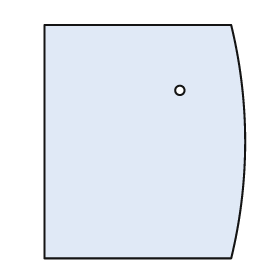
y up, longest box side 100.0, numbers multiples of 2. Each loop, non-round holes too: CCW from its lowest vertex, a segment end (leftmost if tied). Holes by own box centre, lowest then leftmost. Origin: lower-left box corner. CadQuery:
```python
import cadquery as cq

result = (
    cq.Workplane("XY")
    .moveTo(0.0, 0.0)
    .lineTo(80.0, 0.0)
    .threePointArc((86.0, 50.0), (80.0, 100.0))
    .lineTo(0.0, 100.0)
    .close()
    .moveTo(58.0, 72.0)
    .circle(2.0)
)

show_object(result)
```